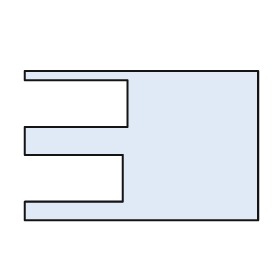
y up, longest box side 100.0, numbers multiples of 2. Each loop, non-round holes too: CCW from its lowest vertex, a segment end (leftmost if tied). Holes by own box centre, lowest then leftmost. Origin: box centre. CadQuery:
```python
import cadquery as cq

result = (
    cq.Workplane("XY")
    .moveTo(-50.0, -32.0)
    .lineTo(50.0, -32.0)
    .lineTo(50.0, 32.0)
    .lineTo(-50.0, 32.0)
    .lineTo(-50.0, 28.0)
    .lineTo(-6.0, 28.0)
    .lineTo(-6.0, 8.0)
    .lineTo(-50.0, 8.0)
    .lineTo(-50.0, -4.0)
    .lineTo(-8.0, -4.0)
    .lineTo(-8.0, -24.0)
    .lineTo(-50.0, -24.0)
    .close()
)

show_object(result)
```